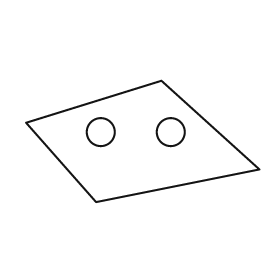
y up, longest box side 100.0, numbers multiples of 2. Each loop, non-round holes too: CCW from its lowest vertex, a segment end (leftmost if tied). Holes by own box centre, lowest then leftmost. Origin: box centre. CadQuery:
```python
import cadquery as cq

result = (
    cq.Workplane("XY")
    .moveTo(-20.0, -26.0)
    .lineTo(50.0, -12.0)
    .lineTo(8.0, 26.0)
    .lineTo(-50.0, 8.0)
    .close()
    .moveTo(-18.0, 4.0)
    .circle(6.0)
    .moveTo(12.0, 4.0)
    .circle(6.0)
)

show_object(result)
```